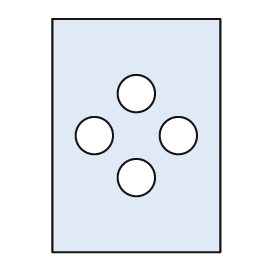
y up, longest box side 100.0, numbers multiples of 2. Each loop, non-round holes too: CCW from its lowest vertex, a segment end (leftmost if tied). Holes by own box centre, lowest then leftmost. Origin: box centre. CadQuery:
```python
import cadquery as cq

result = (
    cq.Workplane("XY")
    .moveTo(-36.0, -50.0)
    .lineTo(36.0, -50.0)
    .lineTo(36.0, 50.0)
    .lineTo(-36.0, 50.0)
    .close()
    .moveTo(0.0, -18.0)
    .circle(8.0)
    .moveTo(-18.0, 0.0)
    .circle(8.0)
    .moveTo(18.0, 0.0)
    .circle(8.0)
    .moveTo(0.0, 18.0)
    .circle(8.0)
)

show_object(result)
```